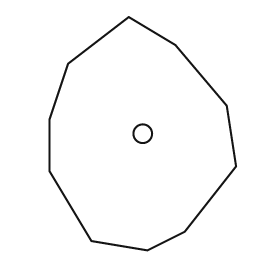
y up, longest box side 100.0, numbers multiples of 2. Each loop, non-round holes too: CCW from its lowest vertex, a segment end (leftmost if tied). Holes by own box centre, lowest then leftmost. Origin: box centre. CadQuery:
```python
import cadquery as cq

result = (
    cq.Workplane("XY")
    .moveTo(2.0, -50.0)
    .lineTo(18.0, -42.0)
    .lineTo(40.0, -14.0)
    .lineTo(36.0, 12.0)
    .lineTo(14.0, 38.0)
    .lineTo(-6.0, 50.0)
    .lineTo(-32.0, 30.0)
    .lineTo(-40.0, 6.0)
    .lineTo(-40.0, -16.0)
    .lineTo(-22.0, -46.0)
    .close()
    .moveTo(0.0, 0.0)
    .circle(4.0)
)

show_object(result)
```